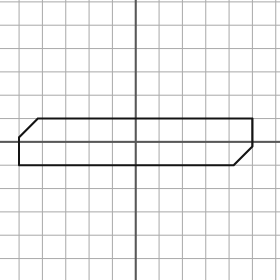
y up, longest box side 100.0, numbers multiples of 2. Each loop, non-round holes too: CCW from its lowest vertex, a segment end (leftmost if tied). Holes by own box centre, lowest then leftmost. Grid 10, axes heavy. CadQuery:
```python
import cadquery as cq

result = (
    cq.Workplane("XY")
    .moveTo(-50.0, -10.0)
    .lineTo(42.0, -10.0)
    .lineTo(50.0, -2.0)
    .lineTo(50.0, 10.0)
    .lineTo(-42.0, 10.0)
    .lineTo(-50.0, 2.0)
    .close()
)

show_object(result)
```